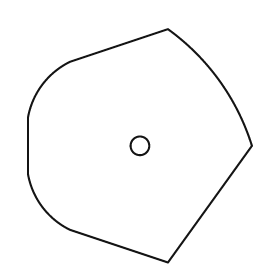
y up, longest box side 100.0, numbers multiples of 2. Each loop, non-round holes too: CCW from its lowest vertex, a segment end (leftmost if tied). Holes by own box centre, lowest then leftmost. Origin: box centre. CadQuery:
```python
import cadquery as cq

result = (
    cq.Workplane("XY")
    .moveTo(12.0, -50.0)
    .lineTo(48.0, 0.0)
    .threePointArc((34.0, 28.0), (12.0, 50.0))
    .lineTo(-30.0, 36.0)
    .threePointArc((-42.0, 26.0), (-48.0, 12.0))
    .lineTo(-48.0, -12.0)
    .threePointArc((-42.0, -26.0), (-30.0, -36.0))
    .close()
    .moveTo(0.0, 0.0)
    .circle(4.0)
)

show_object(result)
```